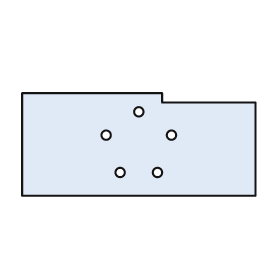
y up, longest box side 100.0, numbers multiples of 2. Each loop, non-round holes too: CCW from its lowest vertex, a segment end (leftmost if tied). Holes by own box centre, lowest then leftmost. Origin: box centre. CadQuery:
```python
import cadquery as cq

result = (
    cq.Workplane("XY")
    .moveTo(-50.0, -22.0)
    .lineTo(50.0, -22.0)
    .lineTo(50.0, 18.0)
    .lineTo(10.0, 18.0)
    .lineTo(10.0, 22.0)
    .lineTo(-50.0, 22.0)
    .close()
    .moveTo(-8.0, -12.0)
    .circle(2.0)
    .moveTo(8.0, -12.0)
    .circle(2.0)
    .moveTo(-14.0, 4.0)
    .circle(2.0)
    .moveTo(14.0, 4.0)
    .circle(2.0)
    .moveTo(0.0, 14.0)
    .circle(2.0)
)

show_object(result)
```